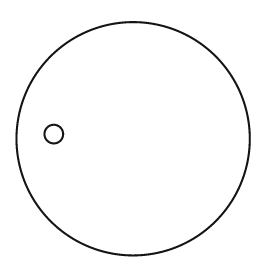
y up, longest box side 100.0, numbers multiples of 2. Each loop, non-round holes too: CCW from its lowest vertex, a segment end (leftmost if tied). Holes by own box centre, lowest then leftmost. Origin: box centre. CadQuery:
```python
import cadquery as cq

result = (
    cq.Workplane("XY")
    .moveTo(0.0, 0.0)
    .circle(50.0)
    .moveTo(-34.0, 2.0)
    .circle(4.0)
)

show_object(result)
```